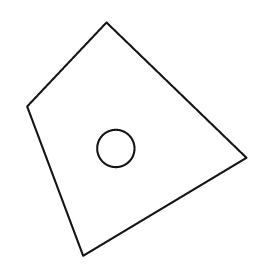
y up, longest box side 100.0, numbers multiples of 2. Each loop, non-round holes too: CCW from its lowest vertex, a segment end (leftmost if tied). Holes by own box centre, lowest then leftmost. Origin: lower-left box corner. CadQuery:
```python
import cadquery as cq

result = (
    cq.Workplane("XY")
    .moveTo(24.0, 0.0)
    .lineTo(94.0, 42.0)
    .lineTo(34.0, 100.0)
    .lineTo(0.0, 64.0)
    .close()
    .moveTo(38.0, 46.0)
    .circle(8.0)
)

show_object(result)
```